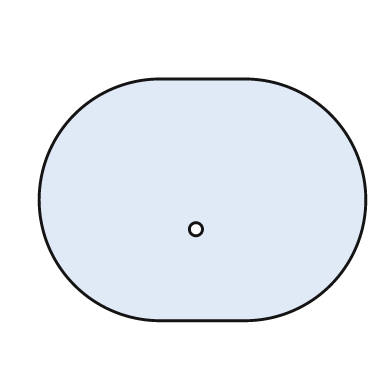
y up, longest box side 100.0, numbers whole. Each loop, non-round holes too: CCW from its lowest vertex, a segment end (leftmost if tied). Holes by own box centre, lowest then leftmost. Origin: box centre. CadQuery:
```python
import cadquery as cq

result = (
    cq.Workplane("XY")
    .moveTo(-13.0, -37.0)
    .lineTo(13.0, -37.0)
    .threePointArc((50.0, 0.0), (13.0, 37.0))
    .lineTo(-13.0, 37.0)
    .threePointArc((-50.0, 0.0), (-13.0, -37.0))
    .close()
    .moveTo(-2.0, -9.0)
    .circle(2.0)
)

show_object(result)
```